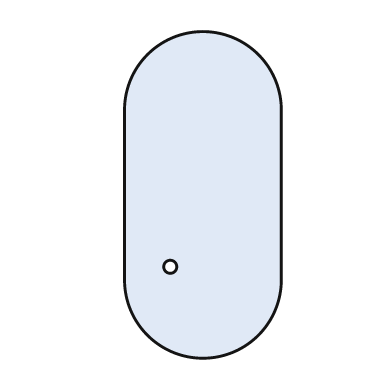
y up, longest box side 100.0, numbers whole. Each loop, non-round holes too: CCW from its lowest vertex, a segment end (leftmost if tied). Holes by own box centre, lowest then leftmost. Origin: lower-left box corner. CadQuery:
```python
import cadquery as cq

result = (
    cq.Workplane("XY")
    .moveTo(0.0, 24.0)
    .threePointArc((24.0, 0.0), (48.0, 24.0))
    .lineTo(48.0, 76.0)
    .threePointArc((24.0, 100.0), (0.0, 76.0))
    .close()
    .moveTo(14.0, 28.0)
    .circle(2.0)
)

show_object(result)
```